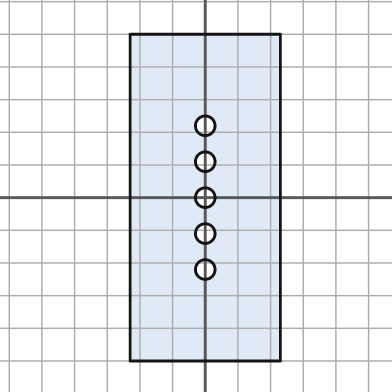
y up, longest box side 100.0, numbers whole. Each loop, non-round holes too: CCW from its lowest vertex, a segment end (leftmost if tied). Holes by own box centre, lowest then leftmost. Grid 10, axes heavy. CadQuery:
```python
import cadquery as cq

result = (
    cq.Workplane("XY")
    .moveTo(-23.0, -50.0)
    .lineTo(23.0, -50.0)
    .lineTo(23.0, 50.0)
    .lineTo(-23.0, 50.0)
    .close()
    .moveTo(0.0, -22.0)
    .circle(3.0)
    .moveTo(0.0, -11.0)
    .circle(3.0)
    .moveTo(0.0, 0.0)
    .circle(3.0)
    .moveTo(0.0, 11.0)
    .circle(3.0)
    .moveTo(0.0, 22.0)
    .circle(3.0)
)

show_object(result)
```